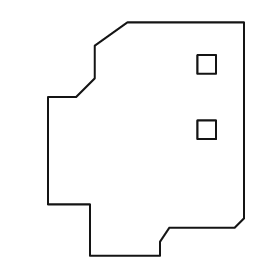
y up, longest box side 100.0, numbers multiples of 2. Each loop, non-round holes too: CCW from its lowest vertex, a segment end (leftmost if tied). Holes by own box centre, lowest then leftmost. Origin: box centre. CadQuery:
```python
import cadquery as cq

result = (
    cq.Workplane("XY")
    .moveTo(-24.0, -50.0)
    .lineTo(6.0, -50.0)
    .lineTo(6.0, -44.0)
    .lineTo(10.0, -38.0)
    .lineTo(38.0, -38.0)
    .lineTo(42.0, -34.0)
    .lineTo(42.0, 50.0)
    .lineTo(-8.0, 50.0)
    .lineTo(-22.0, 40.0)
    .lineTo(-22.0, 26.0)
    .lineTo(-30.0, 18.0)
    .lineTo(-42.0, 18.0)
    .lineTo(-42.0, -28.0)
    .lineTo(-24.0, -28.0)
    .close()
    .moveTo(22.0, 0.0)
    .lineTo(30.0, 0.0)
    .lineTo(30.0, 8.0)
    .lineTo(22.0, 8.0)
    .close()
    .moveTo(22.0, 28.0)
    .lineTo(30.0, 28.0)
    .lineTo(30.0, 36.0)
    .lineTo(22.0, 36.0)
    .close()
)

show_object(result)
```